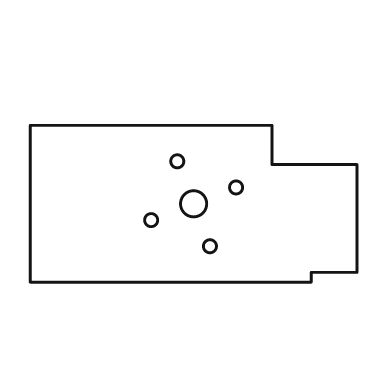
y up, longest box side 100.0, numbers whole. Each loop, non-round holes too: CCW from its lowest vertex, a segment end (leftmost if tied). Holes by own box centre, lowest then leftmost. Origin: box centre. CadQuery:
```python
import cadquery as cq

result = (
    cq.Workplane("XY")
    .moveTo(-50.0, -24.0)
    .lineTo(36.0, -24.0)
    .lineTo(36.0, -21.0)
    .lineTo(50.0, -21.0)
    .lineTo(50.0, 12.0)
    .lineTo(24.0, 12.0)
    .lineTo(24.0, 24.0)
    .lineTo(-50.0, 24.0)
    .close()
    .moveTo(5.0, -13.0)
    .circle(2.0)
    .moveTo(-13.0, -5.0)
    .circle(2.0)
    .moveTo(0.0, 0.0)
    .circle(4.0)
    .moveTo(13.0, 5.0)
    .circle(2.0)
    .moveTo(-5.0, 13.0)
    .circle(2.0)
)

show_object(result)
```